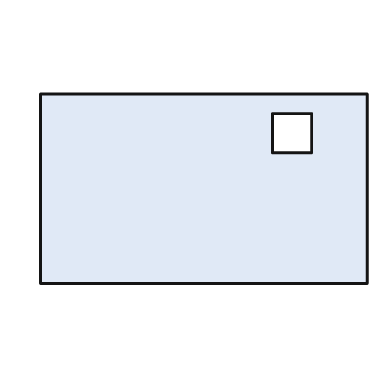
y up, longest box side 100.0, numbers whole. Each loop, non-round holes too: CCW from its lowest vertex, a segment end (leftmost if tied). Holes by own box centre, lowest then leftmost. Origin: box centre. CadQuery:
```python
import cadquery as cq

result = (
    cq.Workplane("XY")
    .moveTo(-50.0, -29.0)
    .lineTo(50.0, -29.0)
    .lineTo(50.0, 29.0)
    .lineTo(-50.0, 29.0)
    .close()
    .moveTo(21.0, 11.0)
    .lineTo(33.0, 11.0)
    .lineTo(33.0, 23.0)
    .lineTo(21.0, 23.0)
    .close()
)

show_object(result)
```